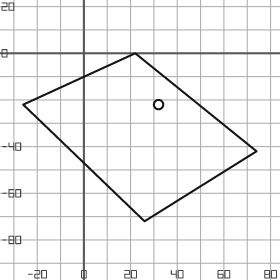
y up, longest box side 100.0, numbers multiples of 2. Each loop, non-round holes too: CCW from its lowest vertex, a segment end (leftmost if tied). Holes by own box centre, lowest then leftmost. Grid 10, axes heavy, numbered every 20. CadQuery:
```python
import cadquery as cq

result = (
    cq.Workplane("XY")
    .moveTo(26.0, -72.0)
    .lineTo(74.0, -42.0)
    .lineTo(22.0, 0.0)
    .lineTo(-26.0, -22.0)
    .close()
    .moveTo(32.0, -22.0)
    .circle(2.0)
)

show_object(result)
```